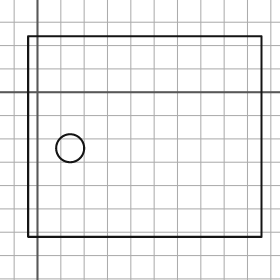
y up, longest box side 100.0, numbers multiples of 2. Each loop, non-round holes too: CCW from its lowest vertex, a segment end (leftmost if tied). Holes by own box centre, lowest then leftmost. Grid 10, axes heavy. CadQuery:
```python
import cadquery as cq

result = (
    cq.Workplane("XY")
    .moveTo(-4.0, -62.0)
    .lineTo(96.0, -62.0)
    .lineTo(96.0, 24.0)
    .lineTo(-4.0, 24.0)
    .close()
    .moveTo(14.0, -24.0)
    .circle(6.0)
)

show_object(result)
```